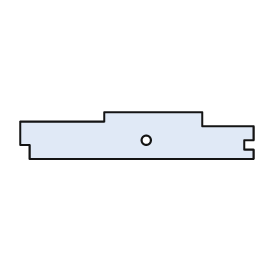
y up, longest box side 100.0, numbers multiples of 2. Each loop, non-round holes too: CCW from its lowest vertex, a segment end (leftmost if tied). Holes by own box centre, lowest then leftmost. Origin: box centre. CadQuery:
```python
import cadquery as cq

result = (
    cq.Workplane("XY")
    .moveTo(-46.0, -10.0)
    .lineTo(50.0, -10.0)
    .lineTo(50.0, -6.0)
    .lineTo(46.0, -6.0)
    .lineTo(46.0, -2.0)
    .lineTo(50.0, -2.0)
    .lineTo(50.0, 4.0)
    .lineTo(28.0, 4.0)
    .lineTo(28.0, 10.0)
    .lineTo(-14.0, 10.0)
    .lineTo(-14.0, 6.0)
    .lineTo(-50.0, 6.0)
    .lineTo(-50.0, -4.0)
    .lineTo(-46.0, -4.0)
    .close()
    .moveTo(4.0, -2.0)
    .circle(2.0)
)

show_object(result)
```